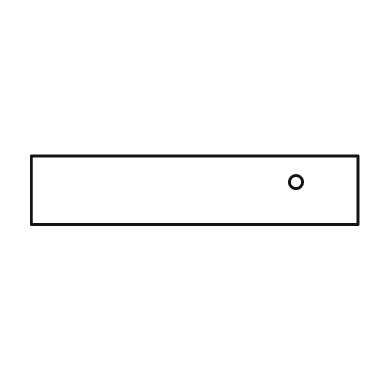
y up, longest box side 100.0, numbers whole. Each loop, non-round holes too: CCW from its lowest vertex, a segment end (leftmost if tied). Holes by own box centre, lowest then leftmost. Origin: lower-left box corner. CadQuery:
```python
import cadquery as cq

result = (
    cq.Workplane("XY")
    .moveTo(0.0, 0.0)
    .lineTo(100.0, 0.0)
    .lineTo(100.0, 21.0)
    .lineTo(0.0, 21.0)
    .close()
    .moveTo(81.0, 13.0)
    .circle(2.0)
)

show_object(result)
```